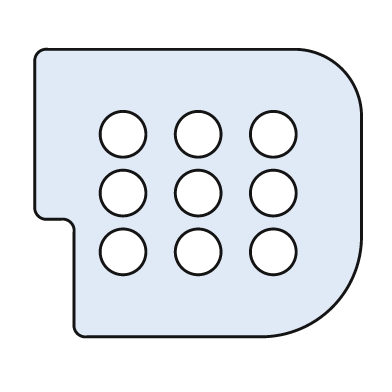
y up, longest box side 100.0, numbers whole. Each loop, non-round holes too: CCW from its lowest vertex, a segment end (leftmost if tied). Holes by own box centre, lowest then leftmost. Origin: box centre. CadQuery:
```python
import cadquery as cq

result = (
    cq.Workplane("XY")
    .moveTo(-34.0, -44.0)
    .lineTo(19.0, -44.0)
    .threePointArc((41.0, -35.0), (50.0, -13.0))
    .lineTo(50.0, 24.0)
    .threePointArc((44.0, 38.0), (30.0, 44.0))
    .lineTo(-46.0, 44.0)
    .threePointArc((-49.0, 43.0), (-50.0, 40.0))
    .lineTo(-50.0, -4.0)
    .threePointArc((-49.0, -7.0), (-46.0, -8.0))
    .lineTo(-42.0, -8.0)
    .threePointArc((-39.0, -9.0), (-38.0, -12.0))
    .lineTo(-38.0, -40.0)
    .threePointArc((-37.0, -43.0), (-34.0, -44.0))
    .close()
    .moveTo(-23.0, -18.0)
    .circle(7.0)
    .moveTo(0.0, -18.0)
    .circle(7.0)
    .moveTo(23.0, -18.0)
    .circle(7.0)
    .moveTo(-23.0, 0.0)
    .circle(7.0)
    .moveTo(0.0, 0.0)
    .circle(7.0)
    .moveTo(23.0, 0.0)
    .circle(7.0)
    .moveTo(-23.0, 18.0)
    .circle(7.0)
    .moveTo(0.0, 18.0)
    .circle(7.0)
    .moveTo(23.0, 18.0)
    .circle(7.0)
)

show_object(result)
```